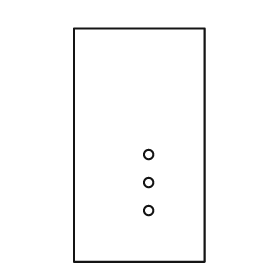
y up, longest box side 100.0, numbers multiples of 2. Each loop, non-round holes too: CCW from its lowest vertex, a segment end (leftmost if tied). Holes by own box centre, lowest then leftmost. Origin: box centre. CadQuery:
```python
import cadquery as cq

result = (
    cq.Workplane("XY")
    .moveTo(-28.0, -50.0)
    .lineTo(28.0, -50.0)
    .lineTo(28.0, 50.0)
    .lineTo(-28.0, 50.0)
    .close()
    .moveTo(4.0, -28.0)
    .circle(2.0)
    .moveTo(4.0, -16.0)
    .circle(2.0)
    .moveTo(4.0, -4.0)
    .circle(2.0)
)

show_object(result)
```